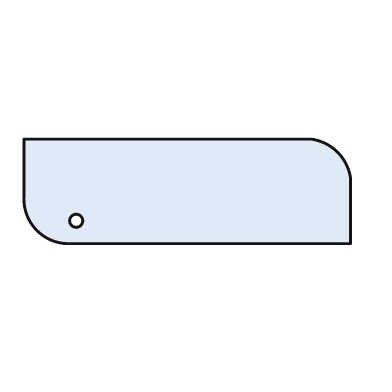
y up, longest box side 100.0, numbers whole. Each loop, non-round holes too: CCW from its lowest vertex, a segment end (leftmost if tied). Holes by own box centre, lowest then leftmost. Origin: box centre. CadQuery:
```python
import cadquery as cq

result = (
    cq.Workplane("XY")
    .moveTo(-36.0, -16.0)
    .lineTo(50.0, -16.0)
    .lineTo(50.0, 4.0)
    .threePointArc((46.0, 12.0), (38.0, 16.0))
    .lineTo(-50.0, 16.0)
    .lineTo(-50.0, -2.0)
    .threePointArc((-46.0, -12.0), (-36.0, -16.0))
    .close()
    .moveTo(-34.0, -9.0)
    .circle(2.0)
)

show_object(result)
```